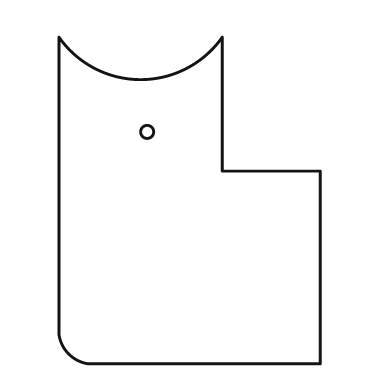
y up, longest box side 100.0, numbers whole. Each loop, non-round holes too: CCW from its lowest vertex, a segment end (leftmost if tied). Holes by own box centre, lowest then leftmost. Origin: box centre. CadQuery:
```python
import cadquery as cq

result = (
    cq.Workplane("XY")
    .moveTo(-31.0, -50.0)
    .lineTo(40.0, -50.0)
    .lineTo(40.0, 9.0)
    .lineTo(10.0, 9.0)
    .lineTo(10.0, 50.0)
    .threePointArc((-15.0, 37.0), (-40.0, 50.0))
    .lineTo(-40.0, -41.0)
    .threePointArc((-37.0, -47.0), (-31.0, -50.0))
    .close()
    .moveTo(-13.0, 21.0)
    .circle(2.0)
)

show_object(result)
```